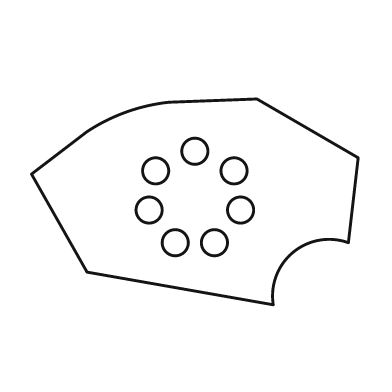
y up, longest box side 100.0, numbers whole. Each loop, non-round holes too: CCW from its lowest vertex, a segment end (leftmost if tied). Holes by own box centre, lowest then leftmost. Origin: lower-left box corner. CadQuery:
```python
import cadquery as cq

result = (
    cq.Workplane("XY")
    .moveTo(74.0, 0.0)
    .threePointArc((80.0, 16.0), (97.0, 19.0))
    .lineTo(100.0, 45.0)
    .lineTo(69.0, 63.0)
    .lineTo(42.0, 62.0)
    .threePointArc((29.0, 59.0), (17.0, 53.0))
    .lineTo(0.0, 40.0)
    .lineTo(17.0, 10.0)
    .close()
    .moveTo(44.0, 19.0)
    .circle(4.0)
    .moveTo(56.0, 19.0)
    .circle(4.0)
    .moveTo(36.0, 29.0)
    .circle(4.0)
    .moveTo(64.0, 29.0)
    .circle(4.0)
    .moveTo(38.0, 41.0)
    .circle(4.0)
    .moveTo(62.0, 41.0)
    .circle(4.0)
    .moveTo(50.0, 47.0)
    .circle(4.0)
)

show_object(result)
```